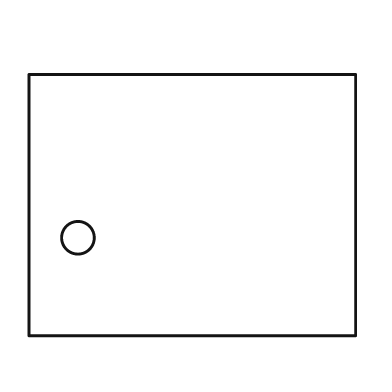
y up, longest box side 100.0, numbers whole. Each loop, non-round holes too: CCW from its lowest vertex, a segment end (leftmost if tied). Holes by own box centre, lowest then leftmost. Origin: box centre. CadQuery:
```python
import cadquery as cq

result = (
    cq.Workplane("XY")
    .moveTo(-50.0, -40.0)
    .lineTo(50.0, -40.0)
    .lineTo(50.0, 40.0)
    .lineTo(-50.0, 40.0)
    .close()
    .moveTo(-35.0, -10.0)
    .circle(5.0)
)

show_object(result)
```